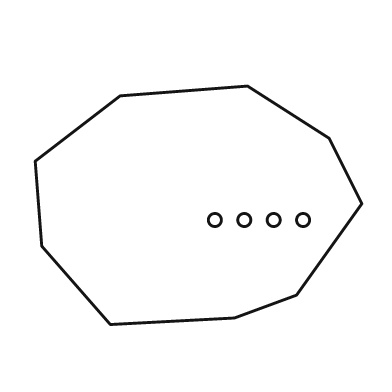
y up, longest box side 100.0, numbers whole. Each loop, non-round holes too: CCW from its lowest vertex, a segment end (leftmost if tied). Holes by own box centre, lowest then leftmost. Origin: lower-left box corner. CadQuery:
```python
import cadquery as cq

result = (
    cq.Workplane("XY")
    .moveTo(23.0, 0.0)
    .lineTo(61.0, 2.0)
    .lineTo(80.0, 9.0)
    .lineTo(100.0, 37.0)
    .lineTo(90.0, 57.0)
    .lineTo(65.0, 73.0)
    .lineTo(26.0, 70.0)
    .lineTo(0.0, 50.0)
    .lineTo(2.0, 24.0)
    .close()
    .moveTo(55.0, 32.0)
    .circle(2.0)
    .moveTo(64.0, 32.0)
    .circle(2.0)
    .moveTo(73.0, 32.0)
    .circle(2.0)
    .moveTo(82.0, 32.0)
    .circle(2.0)
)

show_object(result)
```